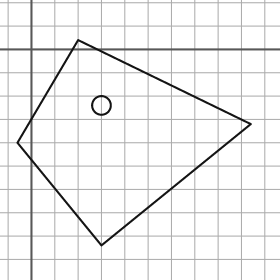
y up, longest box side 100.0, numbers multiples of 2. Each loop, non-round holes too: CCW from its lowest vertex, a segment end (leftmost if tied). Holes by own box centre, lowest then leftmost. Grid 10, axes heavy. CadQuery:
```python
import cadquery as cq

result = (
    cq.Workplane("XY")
    .moveTo(30.0, -84.0)
    .lineTo(94.0, -32.0)
    .lineTo(20.0, 4.0)
    .lineTo(-6.0, -40.0)
    .close()
    .moveTo(30.0, -24.0)
    .circle(4.0)
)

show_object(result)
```